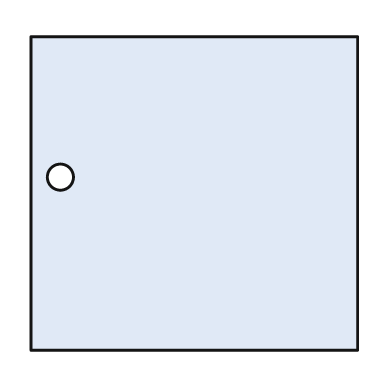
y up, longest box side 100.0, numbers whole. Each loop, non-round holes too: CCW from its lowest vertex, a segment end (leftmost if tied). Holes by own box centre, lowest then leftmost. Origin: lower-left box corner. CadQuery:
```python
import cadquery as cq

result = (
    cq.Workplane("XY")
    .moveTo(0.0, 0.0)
    .lineTo(100.0, 0.0)
    .lineTo(100.0, 96.0)
    .lineTo(0.0, 96.0)
    .close()
    .moveTo(9.0, 53.0)
    .circle(4.0)
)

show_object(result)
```